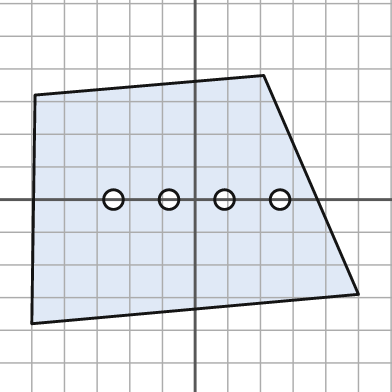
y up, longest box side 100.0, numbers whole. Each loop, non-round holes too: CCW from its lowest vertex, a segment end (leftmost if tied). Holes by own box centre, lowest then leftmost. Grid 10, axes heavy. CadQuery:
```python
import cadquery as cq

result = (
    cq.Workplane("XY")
    .moveTo(-50.0, -38.0)
    .lineTo(50.0, -29.0)
    .lineTo(21.0, 38.0)
    .lineTo(-49.0, 32.0)
    .close()
    .moveTo(-25.0, 0.0)
    .circle(3.0)
    .moveTo(-8.0, 0.0)
    .circle(3.0)
    .moveTo(9.0, 0.0)
    .circle(3.0)
    .moveTo(26.0, 0.0)
    .circle(3.0)
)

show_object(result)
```